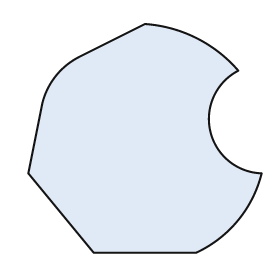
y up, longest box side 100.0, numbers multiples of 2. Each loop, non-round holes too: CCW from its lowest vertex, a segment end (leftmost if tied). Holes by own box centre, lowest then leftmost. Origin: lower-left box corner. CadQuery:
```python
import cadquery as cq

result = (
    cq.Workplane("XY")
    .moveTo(28.0, 0.0)
    .lineTo(72.0, 0.0)
    .threePointArc((90.0, 14.0), (100.0, 34.0))
    .threePointArc((78.0, 52.0), (90.0, 78.0))
    .threePointArc((72.0, 92.0), (50.0, 98.0))
    .lineTo(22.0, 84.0)
    .threePointArc((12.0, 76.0), (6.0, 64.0))
    .lineTo(0.0, 34.0)
    .close()
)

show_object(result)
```